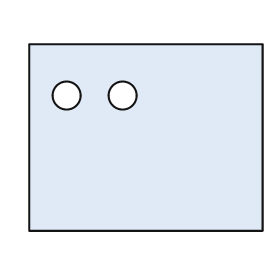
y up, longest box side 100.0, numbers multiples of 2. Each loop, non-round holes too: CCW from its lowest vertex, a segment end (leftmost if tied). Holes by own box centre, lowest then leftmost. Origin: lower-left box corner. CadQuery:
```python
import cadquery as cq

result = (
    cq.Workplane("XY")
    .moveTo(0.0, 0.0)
    .lineTo(100.0, 0.0)
    .lineTo(100.0, 80.0)
    .lineTo(0.0, 80.0)
    .close()
    .moveTo(16.0, 58.0)
    .circle(6.0)
    .moveTo(40.0, 58.0)
    .circle(6.0)
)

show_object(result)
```